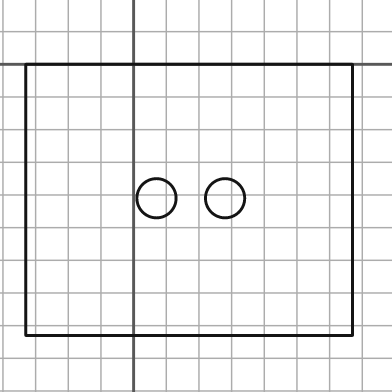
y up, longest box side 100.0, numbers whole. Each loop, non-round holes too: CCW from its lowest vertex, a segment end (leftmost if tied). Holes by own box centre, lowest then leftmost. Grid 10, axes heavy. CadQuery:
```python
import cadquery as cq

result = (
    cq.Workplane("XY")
    .moveTo(-33.0, -83.0)
    .lineTo(67.0, -83.0)
    .lineTo(67.0, 0.0)
    .lineTo(-33.0, 0.0)
    .close()
    .moveTo(7.0, -41.0)
    .circle(6.0)
    .moveTo(28.0, -41.0)
    .circle(6.0)
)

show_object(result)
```